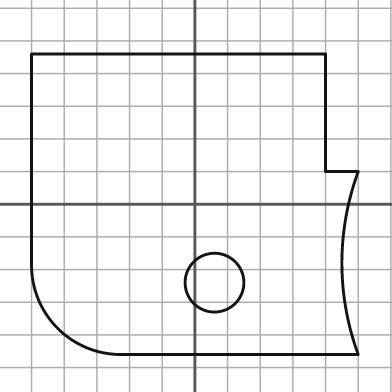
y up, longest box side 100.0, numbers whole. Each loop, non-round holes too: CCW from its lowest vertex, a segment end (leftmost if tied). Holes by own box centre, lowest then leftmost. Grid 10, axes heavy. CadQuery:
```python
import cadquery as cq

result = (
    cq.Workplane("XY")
    .moveTo(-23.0, -46.0)
    .lineTo(50.0, -46.0)
    .threePointArc((45.0, -18.0), (50.0, 10.0))
    .lineTo(40.0, 10.0)
    .lineTo(40.0, 46.0)
    .lineTo(-50.0, 46.0)
    .lineTo(-50.0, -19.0)
    .threePointArc((-42.0, -38.0), (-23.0, -46.0))
    .close()
    .moveTo(6.0, -24.0)
    .circle(9.0)
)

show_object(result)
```